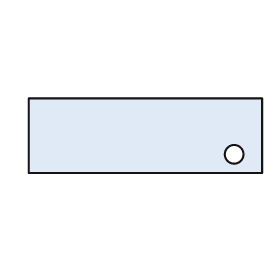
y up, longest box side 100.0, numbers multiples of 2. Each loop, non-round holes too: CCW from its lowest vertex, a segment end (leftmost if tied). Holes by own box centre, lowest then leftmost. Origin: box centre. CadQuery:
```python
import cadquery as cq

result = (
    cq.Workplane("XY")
    .moveTo(-50.0, -16.0)
    .lineTo(50.0, -16.0)
    .lineTo(50.0, 16.0)
    .lineTo(-50.0, 16.0)
    .close()
    .moveTo(38.0, -8.0)
    .circle(4.0)
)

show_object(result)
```